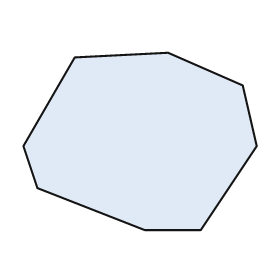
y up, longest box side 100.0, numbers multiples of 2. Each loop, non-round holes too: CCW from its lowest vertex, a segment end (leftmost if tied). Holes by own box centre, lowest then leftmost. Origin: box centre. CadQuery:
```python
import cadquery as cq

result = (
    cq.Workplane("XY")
    .moveTo(2.0, -38.0)
    .lineTo(26.0, -38.0)
    .lineTo(50.0, -2.0)
    .lineTo(44.0, 24.0)
    .lineTo(12.0, 38.0)
    .lineTo(-28.0, 36.0)
    .lineTo(-50.0, -2.0)
    .lineTo(-44.0, -20.0)
    .close()
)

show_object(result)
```